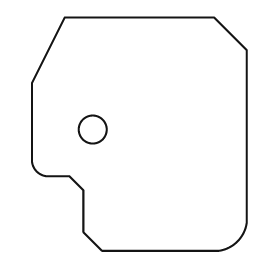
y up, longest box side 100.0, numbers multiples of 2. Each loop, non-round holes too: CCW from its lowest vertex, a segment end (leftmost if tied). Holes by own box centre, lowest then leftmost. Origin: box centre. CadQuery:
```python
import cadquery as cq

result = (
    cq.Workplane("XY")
    .moveTo(-16.0, -50.0)
    .lineTo(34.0, -50.0)
    .threePointArc((42.0, -46.0), (46.0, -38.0))
    .lineTo(46.0, 36.0)
    .lineTo(32.0, 50.0)
    .lineTo(-32.0, 50.0)
    .lineTo(-46.0, 22.0)
    .lineTo(-46.0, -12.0)
    .threePointArc((-44.0, -16.0), (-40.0, -18.0))
    .lineTo(-30.0, -18.0)
    .lineTo(-24.0, -24.0)
    .lineTo(-24.0, -42.0)
    .close()
    .moveTo(-20.0, 2.0)
    .circle(6.0)
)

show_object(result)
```